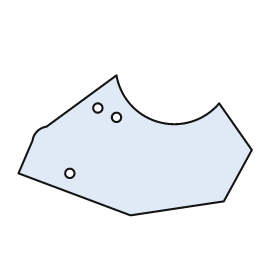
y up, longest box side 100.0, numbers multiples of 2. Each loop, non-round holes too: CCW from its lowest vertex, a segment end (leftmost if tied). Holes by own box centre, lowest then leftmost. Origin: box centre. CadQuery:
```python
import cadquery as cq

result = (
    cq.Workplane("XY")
    .moveTo(-2.0, -30.0)
    .lineTo(38.0, -24.0)
    .lineTo(50.0, -2.0)
    .lineTo(36.0, 18.0)
    .threePointArc((10.0, 10.0), (-8.0, 30.0))
    .lineTo(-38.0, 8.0)
    .threePointArc((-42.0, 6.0), (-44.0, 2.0))
    .lineTo(-50.0, -12.0)
    .close()
    .moveTo(-28.0, -12.0)
    .circle(2.0)
    .moveTo(-8.0, 12.0)
    .circle(2.0)
    .moveTo(-16.0, 16.0)
    .circle(2.0)
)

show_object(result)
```